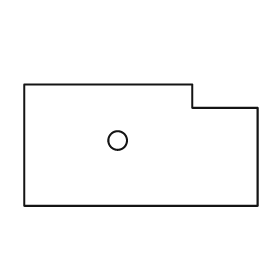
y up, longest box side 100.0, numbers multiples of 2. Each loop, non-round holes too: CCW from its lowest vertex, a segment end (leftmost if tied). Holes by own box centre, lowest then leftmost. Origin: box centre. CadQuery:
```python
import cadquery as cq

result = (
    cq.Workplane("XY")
    .moveTo(-50.0, -26.0)
    .lineTo(50.0, -26.0)
    .lineTo(50.0, 16.0)
    .lineTo(22.0, 16.0)
    .lineTo(22.0, 26.0)
    .lineTo(-50.0, 26.0)
    .close()
    .moveTo(-10.0, 2.0)
    .circle(4.0)
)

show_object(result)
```